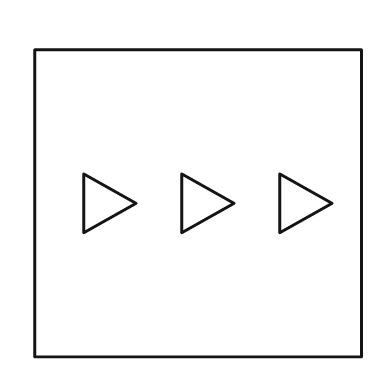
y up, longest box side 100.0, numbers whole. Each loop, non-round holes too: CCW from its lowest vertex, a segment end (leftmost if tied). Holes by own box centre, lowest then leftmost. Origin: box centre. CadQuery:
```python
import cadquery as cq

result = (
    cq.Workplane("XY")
    .moveTo(-50.0, -47.0)
    .lineTo(50.0, -47.0)
    .lineTo(50.0, 47.0)
    .lineTo(-50.0, 47.0)
    .close()
    .moveTo(-35.0, -9.0)
    .lineTo(-19.0, 0.0)
    .lineTo(-35.0, 9.0)
    .close()
    .moveTo(-5.0, -9.0)
    .lineTo(11.0, 0.0)
    .lineTo(-5.0, 9.0)
    .close()
    .moveTo(25.0, -9.0)
    .lineTo(41.0, 0.0)
    .lineTo(25.0, 9.0)
    .close()
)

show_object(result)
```